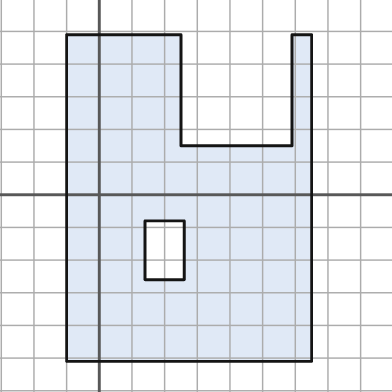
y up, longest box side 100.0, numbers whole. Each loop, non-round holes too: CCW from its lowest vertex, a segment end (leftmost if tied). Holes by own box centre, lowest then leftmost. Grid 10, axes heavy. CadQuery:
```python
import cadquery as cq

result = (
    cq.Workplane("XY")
    .moveTo(-10.0, -51.0)
    .lineTo(65.0, -51.0)
    .lineTo(65.0, 49.0)
    .lineTo(59.0, 49.0)
    .lineTo(59.0, 15.0)
    .lineTo(25.0, 15.0)
    .lineTo(25.0, 49.0)
    .lineTo(-10.0, 49.0)
    .close()
    .moveTo(14.0, -26.0)
    .lineTo(26.0, -26.0)
    .lineTo(26.0, -8.0)
    .lineTo(14.0, -8.0)
    .close()
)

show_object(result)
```